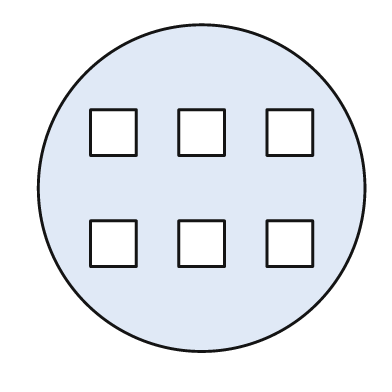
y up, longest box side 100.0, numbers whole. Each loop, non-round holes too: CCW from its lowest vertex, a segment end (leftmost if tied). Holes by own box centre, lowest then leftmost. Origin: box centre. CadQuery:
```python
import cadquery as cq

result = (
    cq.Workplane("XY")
    .moveTo(0.0, 0.0)
    .circle(50.0)
    .moveTo(-34.0, -24.0)
    .lineTo(-20.0, -24.0)
    .lineTo(-20.0, -10.0)
    .lineTo(-34.0, -10.0)
    .close()
    .moveTo(-7.0, -24.0)
    .lineTo(7.0, -24.0)
    .lineTo(7.0, -10.0)
    .lineTo(-7.0, -10.0)
    .close()
    .moveTo(20.0, -24.0)
    .lineTo(34.0, -24.0)
    .lineTo(34.0, -10.0)
    .lineTo(20.0, -10.0)
    .close()
    .moveTo(-34.0, 10.0)
    .lineTo(-20.0, 10.0)
    .lineTo(-20.0, 24.0)
    .lineTo(-34.0, 24.0)
    .close()
    .moveTo(-7.0, 10.0)
    .lineTo(7.0, 10.0)
    .lineTo(7.0, 24.0)
    .lineTo(-7.0, 24.0)
    .close()
    .moveTo(20.0, 10.0)
    .lineTo(34.0, 10.0)
    .lineTo(34.0, 24.0)
    .lineTo(20.0, 24.0)
    .close()
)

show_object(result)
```